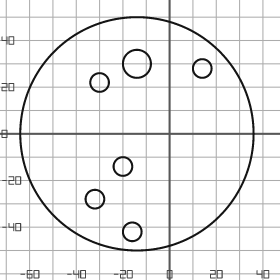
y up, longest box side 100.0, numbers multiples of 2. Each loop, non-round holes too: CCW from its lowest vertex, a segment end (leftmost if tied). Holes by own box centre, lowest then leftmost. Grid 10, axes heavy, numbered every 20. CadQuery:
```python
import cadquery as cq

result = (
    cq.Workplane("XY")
    .moveTo(-14.0, 0.0)
    .circle(50.0)
    .moveTo(-16.0, -42.0)
    .circle(4.0)
    .moveTo(-32.0, -28.0)
    .circle(4.0)
    .moveTo(-20.0, -14.0)
    .circle(4.0)
    .moveTo(-30.0, 22.0)
    .circle(4.0)
    .moveTo(14.0, 28.0)
    .circle(4.0)
    .moveTo(-14.0, 30.0)
    .circle(6.0)
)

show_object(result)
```